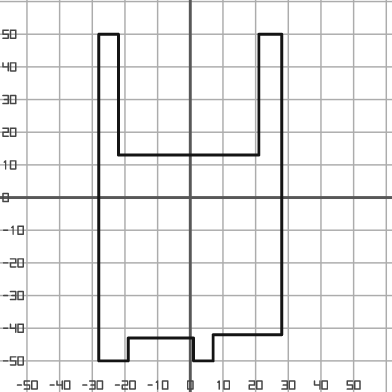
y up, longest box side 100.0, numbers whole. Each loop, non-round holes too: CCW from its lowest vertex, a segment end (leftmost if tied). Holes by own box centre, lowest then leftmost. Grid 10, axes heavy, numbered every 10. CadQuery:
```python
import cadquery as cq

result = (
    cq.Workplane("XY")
    .moveTo(-28.0, -50.0)
    .lineTo(-19.0, -50.0)
    .lineTo(-19.0, -43.0)
    .lineTo(1.0, -43.0)
    .lineTo(1.0, -50.0)
    .lineTo(7.0, -50.0)
    .lineTo(7.0, -42.0)
    .lineTo(28.0, -42.0)
    .lineTo(28.0, 50.0)
    .lineTo(21.0, 50.0)
    .lineTo(21.0, 13.0)
    .lineTo(-22.0, 13.0)
    .lineTo(-22.0, 50.0)
    .lineTo(-28.0, 50.0)
    .close()
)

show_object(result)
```